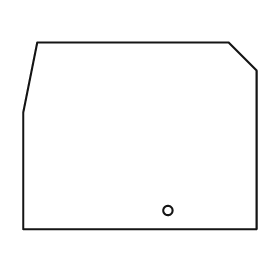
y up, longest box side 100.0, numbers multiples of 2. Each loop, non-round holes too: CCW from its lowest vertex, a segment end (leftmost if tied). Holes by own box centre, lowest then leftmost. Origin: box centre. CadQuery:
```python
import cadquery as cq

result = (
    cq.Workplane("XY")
    .moveTo(-50.0, -40.0)
    .lineTo(50.0, -40.0)
    .lineTo(50.0, 28.0)
    .lineTo(38.0, 40.0)
    .lineTo(-44.0, 40.0)
    .lineTo(-50.0, 10.0)
    .close()
    .moveTo(12.0, -32.0)
    .circle(2.0)
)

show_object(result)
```